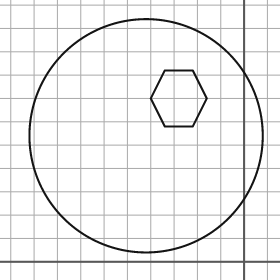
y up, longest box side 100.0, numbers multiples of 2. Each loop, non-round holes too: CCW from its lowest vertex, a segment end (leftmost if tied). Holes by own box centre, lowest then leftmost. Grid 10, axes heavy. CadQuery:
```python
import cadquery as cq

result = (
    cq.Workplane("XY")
    .moveTo(-42.0, 54.0)
    .circle(50.0)
    .moveTo(-34.0, 58.0)
    .lineTo(-22.0, 58.0)
    .lineTo(-16.0, 70.0)
    .lineTo(-22.0, 82.0)
    .lineTo(-34.0, 82.0)
    .lineTo(-40.0, 70.0)
    .close()
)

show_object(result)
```